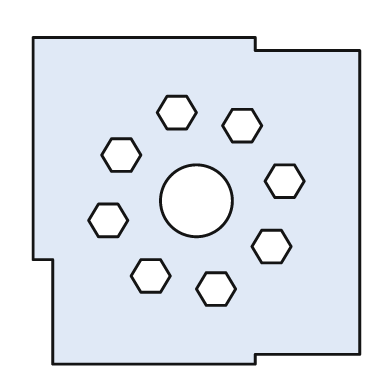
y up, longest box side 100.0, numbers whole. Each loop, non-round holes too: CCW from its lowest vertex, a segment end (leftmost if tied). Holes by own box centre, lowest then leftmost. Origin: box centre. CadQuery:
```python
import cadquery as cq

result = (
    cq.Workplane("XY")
    .moveTo(-44.0, -50.0)
    .lineTo(18.0, -50.0)
    .lineTo(18.0, -47.0)
    .lineTo(50.0, -47.0)
    .lineTo(50.0, 46.0)
    .lineTo(18.0, 46.0)
    .lineTo(18.0, 50.0)
    .lineTo(-50.0, 50.0)
    .lineTo(-50.0, -18.0)
    .lineTo(-44.0, -18.0)
    .close()
    .moveTo(3.0, -32.0)
    .lineTo(9.0, -32.0)
    .lineTo(12.0, -27.0)
    .lineTo(9.0, -22.0)
    .lineTo(3.0, -22.0)
    .lineTo(0.0, -27.0)
    .close()
    .moveTo(-17.0, -28.0)
    .lineTo(-11.0, -28.0)
    .lineTo(-8.0, -23.0)
    .lineTo(-11.0, -18.0)
    .lineTo(-17.0, -18.0)
    .lineTo(-20.0, -23.0)
    .close()
    .moveTo(20.0, -19.0)
    .lineTo(26.0, -19.0)
    .lineTo(29.0, -14.0)
    .lineTo(26.0, -9.0)
    .lineTo(20.0, -9.0)
    .lineTo(17.0, -14.0)
    .close()
    .moveTo(-30.0, -11.0)
    .lineTo(-24.0, -11.0)
    .lineTo(-21.0, -6.0)
    .lineTo(-24.0, -1.0)
    .lineTo(-30.0, -1.0)
    .lineTo(-33.0, -6.0)
    .close()
    .moveTo(0.0, 0.0)
    .circle(11.0)
    .moveTo(24.0, 1.0)
    .lineTo(30.0, 1.0)
    .lineTo(33.0, 6.0)
    .lineTo(30.0, 11.0)
    .lineTo(24.0, 11.0)
    .lineTo(21.0, 6.0)
    .close()
    .moveTo(-26.0, 9.0)
    .lineTo(-20.0, 9.0)
    .lineTo(-17.0, 14.0)
    .lineTo(-20.0, 19.0)
    .lineTo(-26.0, 19.0)
    .lineTo(-29.0, 14.0)
    .close()
    .moveTo(11.0, 18.0)
    .lineTo(17.0, 18.0)
    .lineTo(20.0, 23.0)
    .lineTo(17.0, 28.0)
    .lineTo(11.0, 28.0)
    .lineTo(8.0, 23.0)
    .close()
    .moveTo(-9.0, 22.0)
    .lineTo(-3.0, 22.0)
    .lineTo(0.0, 27.0)
    .lineTo(-3.0, 32.0)
    .lineTo(-9.0, 32.0)
    .lineTo(-12.0, 27.0)
    .close()
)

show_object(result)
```